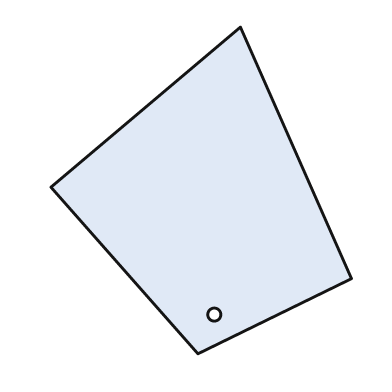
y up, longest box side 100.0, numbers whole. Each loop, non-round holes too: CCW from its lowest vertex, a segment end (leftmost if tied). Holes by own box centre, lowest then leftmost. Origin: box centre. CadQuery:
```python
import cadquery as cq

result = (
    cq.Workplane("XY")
    .moveTo(-1.0, -50.0)
    .lineTo(46.0, -27.0)
    .lineTo(12.0, 50.0)
    .lineTo(-46.0, 1.0)
    .close()
    .moveTo(4.0, -38.0)
    .circle(2.0)
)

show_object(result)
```